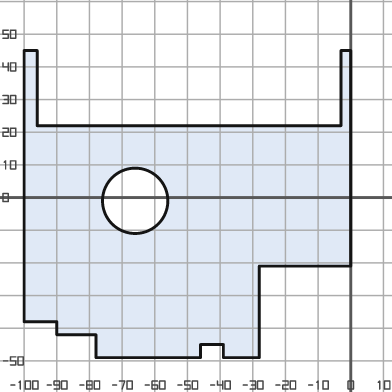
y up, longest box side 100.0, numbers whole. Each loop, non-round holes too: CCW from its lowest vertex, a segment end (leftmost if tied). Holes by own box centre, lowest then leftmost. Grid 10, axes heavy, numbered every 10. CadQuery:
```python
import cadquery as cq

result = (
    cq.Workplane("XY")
    .moveTo(-78.0, -49.0)
    .lineTo(-46.0, -49.0)
    .lineTo(-46.0, -45.0)
    .lineTo(-39.0, -45.0)
    .lineTo(-39.0, -49.0)
    .lineTo(-28.0, -49.0)
    .lineTo(-28.0, -21.0)
    .lineTo(0.0, -21.0)
    .lineTo(0.0, 45.0)
    .lineTo(-3.0, 45.0)
    .lineTo(-3.0, 22.0)
    .lineTo(-96.0, 22.0)
    .lineTo(-96.0, 45.0)
    .lineTo(-100.0, 45.0)
    .lineTo(-100.0, -38.0)
    .lineTo(-90.0, -38.0)
    .lineTo(-90.0, -42.0)
    .lineTo(-78.0, -42.0)
    .close()
    .moveTo(-66.0, -1.0)
    .circle(10.0)
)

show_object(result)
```